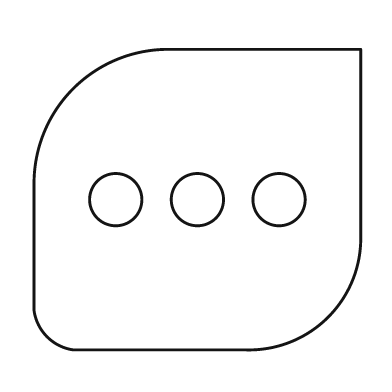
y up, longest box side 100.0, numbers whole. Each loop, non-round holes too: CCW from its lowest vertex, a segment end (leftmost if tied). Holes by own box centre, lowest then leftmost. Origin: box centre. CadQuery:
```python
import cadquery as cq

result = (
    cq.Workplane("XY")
    .moveTo(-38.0, -46.0)
    .lineTo(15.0, -46.0)
    .threePointArc((40.0, -36.0), (50.0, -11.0))
    .lineTo(50.0, 46.0)
    .lineTo(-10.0, 46.0)
    .threePointArc((-38.0, 34.0), (-50.0, 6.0))
    .lineTo(-50.0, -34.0)
    .threePointArc((-46.0, -42.0), (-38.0, -46.0))
    .close()
    .moveTo(-25.0, 0.0)
    .circle(8.0)
    .moveTo(0.0, 0.0)
    .circle(8.0)
    .moveTo(25.0, 0.0)
    .circle(8.0)
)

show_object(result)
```